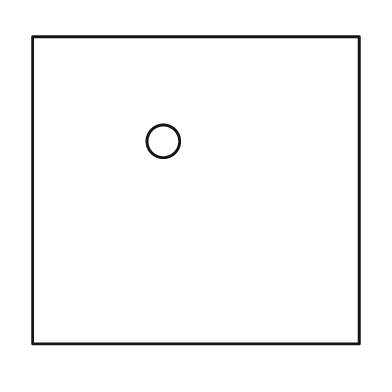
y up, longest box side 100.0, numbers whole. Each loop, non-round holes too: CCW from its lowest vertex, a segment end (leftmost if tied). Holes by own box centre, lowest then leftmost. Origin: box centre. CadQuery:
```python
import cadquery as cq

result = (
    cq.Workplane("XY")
    .moveTo(-50.0, -47.0)
    .lineTo(50.0, -47.0)
    .lineTo(50.0, 47.0)
    .lineTo(-50.0, 47.0)
    .close()
    .moveTo(-10.0, 15.0)
    .circle(5.0)
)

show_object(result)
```